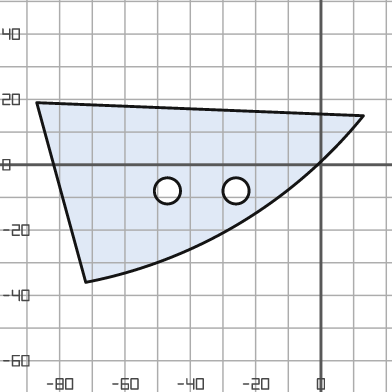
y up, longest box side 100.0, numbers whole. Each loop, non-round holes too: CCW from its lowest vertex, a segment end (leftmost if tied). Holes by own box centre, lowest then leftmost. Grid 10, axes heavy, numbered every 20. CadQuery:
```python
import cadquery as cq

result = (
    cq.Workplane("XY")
    .moveTo(-72.0, -36.0)
    .threePointArc((-25.0, -18.0), (13.0, 15.0))
    .lineTo(-87.0, 19.0)
    .close()
    .moveTo(-47.0, -8.0)
    .circle(4.0)
    .moveTo(-26.0, -8.0)
    .circle(4.0)
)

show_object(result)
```